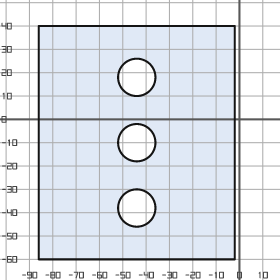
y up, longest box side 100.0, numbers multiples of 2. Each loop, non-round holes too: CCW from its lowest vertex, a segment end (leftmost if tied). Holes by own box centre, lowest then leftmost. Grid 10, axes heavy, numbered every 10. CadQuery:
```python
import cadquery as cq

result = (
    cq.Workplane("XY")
    .moveTo(-86.0, -60.0)
    .lineTo(-2.0, -60.0)
    .lineTo(-2.0, 40.0)
    .lineTo(-86.0, 40.0)
    .close()
    .moveTo(-44.0, -38.0)
    .circle(8.0)
    .moveTo(-44.0, -10.0)
    .circle(8.0)
    .moveTo(-44.0, 18.0)
    .circle(8.0)
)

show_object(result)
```